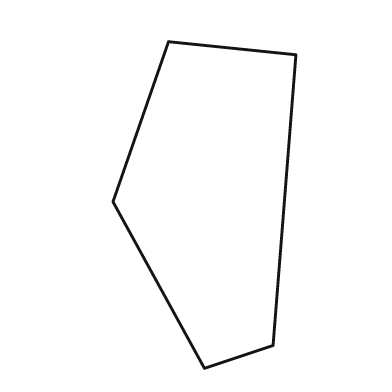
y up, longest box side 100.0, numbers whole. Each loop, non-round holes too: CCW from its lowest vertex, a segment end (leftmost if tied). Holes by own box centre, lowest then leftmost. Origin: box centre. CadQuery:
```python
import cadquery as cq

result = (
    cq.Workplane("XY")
    .moveTo(0.0, -50.0)
    .lineTo(21.0, -43.0)
    .lineTo(28.0, 46.0)
    .lineTo(-11.0, 50.0)
    .lineTo(-28.0, 1.0)
    .close()
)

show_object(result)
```